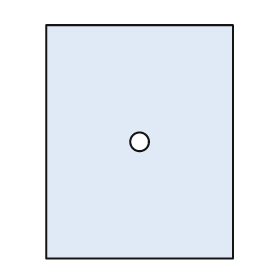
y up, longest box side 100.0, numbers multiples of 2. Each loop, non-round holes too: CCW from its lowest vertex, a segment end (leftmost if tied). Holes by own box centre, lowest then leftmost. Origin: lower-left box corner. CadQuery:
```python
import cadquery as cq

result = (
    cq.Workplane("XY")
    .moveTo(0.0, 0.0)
    .lineTo(80.0, 0.0)
    .lineTo(80.0, 100.0)
    .lineTo(0.0, 100.0)
    .close()
    .moveTo(40.0, 50.0)
    .circle(4.0)
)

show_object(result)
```